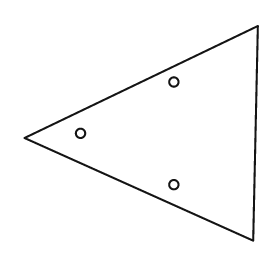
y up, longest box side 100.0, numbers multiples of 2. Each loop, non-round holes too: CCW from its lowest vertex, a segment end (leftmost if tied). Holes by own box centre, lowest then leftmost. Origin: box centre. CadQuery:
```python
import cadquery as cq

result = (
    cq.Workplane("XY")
    .moveTo(48.0, -46.0)
    .lineTo(50.0, 46.0)
    .lineTo(-50.0, -2.0)
    .close()
    .moveTo(14.0, -22.0)
    .circle(2.0)
    .moveTo(-26.0, 0.0)
    .circle(2.0)
    .moveTo(14.0, 22.0)
    .circle(2.0)
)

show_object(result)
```